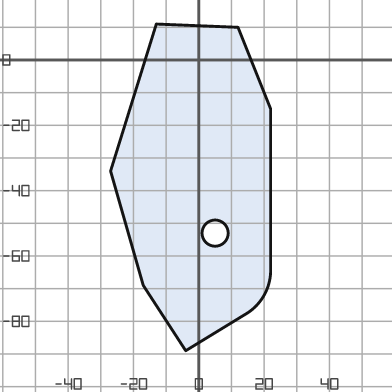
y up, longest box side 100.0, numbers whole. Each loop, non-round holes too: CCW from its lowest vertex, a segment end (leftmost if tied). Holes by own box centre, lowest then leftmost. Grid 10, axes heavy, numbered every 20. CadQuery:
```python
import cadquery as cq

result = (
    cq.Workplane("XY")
    .moveTo(-4.0, -89.0)
    .lineTo(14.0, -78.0)
    .threePointArc((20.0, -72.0), (22.0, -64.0))
    .lineTo(22.0, -15.0)
    .lineTo(12.0, 10.0)
    .lineTo(-13.0, 11.0)
    .lineTo(-27.0, -34.0)
    .lineTo(-17.0, -69.0)
    .close()
    .moveTo(5.0, -53.0)
    .circle(4.0)
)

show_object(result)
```